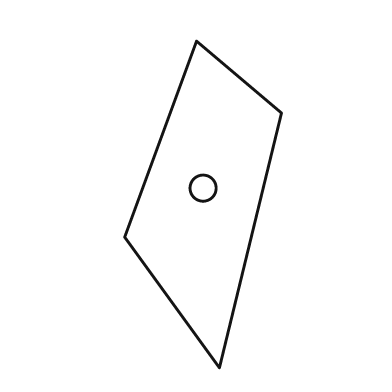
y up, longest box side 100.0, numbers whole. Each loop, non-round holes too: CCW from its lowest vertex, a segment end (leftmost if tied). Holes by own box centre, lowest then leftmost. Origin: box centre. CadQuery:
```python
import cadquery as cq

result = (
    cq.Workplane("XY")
    .moveTo(5.0, -50.0)
    .lineTo(24.0, 28.0)
    .lineTo(-2.0, 50.0)
    .lineTo(-24.0, -10.0)
    .close()
    .moveTo(0.0, 5.0)
    .circle(4.0)
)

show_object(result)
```